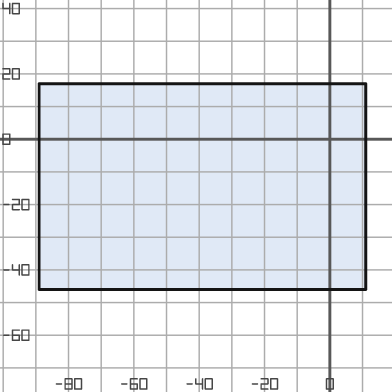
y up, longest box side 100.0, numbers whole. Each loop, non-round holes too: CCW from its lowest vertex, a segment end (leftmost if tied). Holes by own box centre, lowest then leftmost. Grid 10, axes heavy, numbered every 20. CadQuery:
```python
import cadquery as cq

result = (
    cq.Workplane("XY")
    .moveTo(-89.0, -46.0)
    .lineTo(11.0, -46.0)
    .lineTo(11.0, 17.0)
    .lineTo(-89.0, 17.0)
    .close()
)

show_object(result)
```